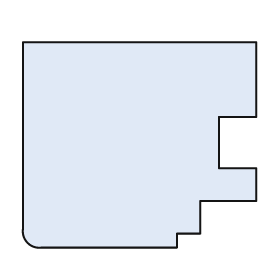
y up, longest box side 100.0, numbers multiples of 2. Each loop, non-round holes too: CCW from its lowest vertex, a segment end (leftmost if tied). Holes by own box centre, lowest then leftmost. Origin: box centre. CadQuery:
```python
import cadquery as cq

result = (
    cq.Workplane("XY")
    .moveTo(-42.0, -44.0)
    .lineTo(16.0, -44.0)
    .lineTo(16.0, -38.0)
    .lineTo(26.0, -38.0)
    .lineTo(26.0, -24.0)
    .lineTo(50.0, -24.0)
    .lineTo(50.0, -10.0)
    .lineTo(34.0, -10.0)
    .lineTo(34.0, 12.0)
    .lineTo(50.0, 12.0)
    .lineTo(50.0, 44.0)
    .lineTo(-50.0, 44.0)
    .lineTo(-50.0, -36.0)
    .threePointArc((-48.0, -42.0), (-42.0, -44.0))
    .close()
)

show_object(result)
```